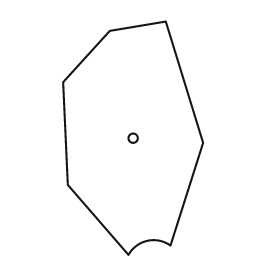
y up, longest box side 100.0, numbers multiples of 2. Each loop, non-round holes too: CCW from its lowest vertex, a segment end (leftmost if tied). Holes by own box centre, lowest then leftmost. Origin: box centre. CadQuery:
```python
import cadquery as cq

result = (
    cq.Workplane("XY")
    .moveTo(-2.0, -50.0)
    .threePointArc((6.0, -44.0), (16.0, -46.0))
    .lineTo(30.0, -2.0)
    .lineTo(14.0, 50.0)
    .lineTo(-10.0, 46.0)
    .lineTo(-30.0, 24.0)
    .lineTo(-28.0, -20.0)
    .close()
    .moveTo(0.0, 0.0)
    .circle(2.0)
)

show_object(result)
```